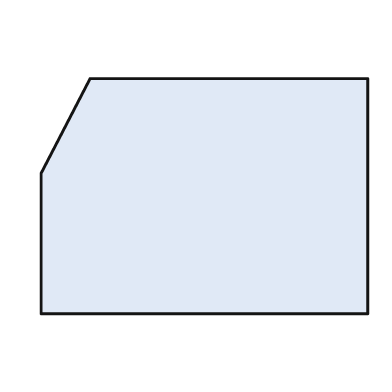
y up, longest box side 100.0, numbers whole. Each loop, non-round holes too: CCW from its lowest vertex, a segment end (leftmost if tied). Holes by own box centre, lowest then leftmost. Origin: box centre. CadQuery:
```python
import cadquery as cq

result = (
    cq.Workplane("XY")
    .moveTo(-50.0, -36.0)
    .lineTo(50.0, -36.0)
    .lineTo(50.0, 36.0)
    .lineTo(-35.0, 36.0)
    .lineTo(-50.0, 7.0)
    .close()
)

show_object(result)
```